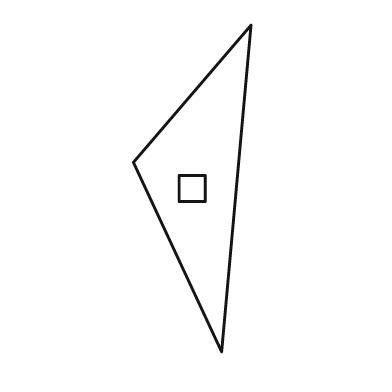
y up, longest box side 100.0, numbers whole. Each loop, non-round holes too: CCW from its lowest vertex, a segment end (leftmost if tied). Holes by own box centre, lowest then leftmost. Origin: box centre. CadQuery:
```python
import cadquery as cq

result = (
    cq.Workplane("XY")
    .moveTo(9.0, -50.0)
    .lineTo(18.0, 50.0)
    .lineTo(-18.0, 8.0)
    .close()
    .moveTo(-4.0, -4.0)
    .lineTo(4.0, -4.0)
    .lineTo(4.0, 4.0)
    .lineTo(-4.0, 4.0)
    .close()
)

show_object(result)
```